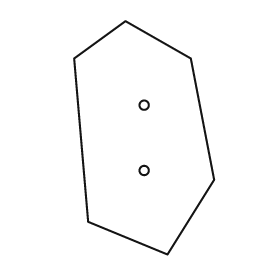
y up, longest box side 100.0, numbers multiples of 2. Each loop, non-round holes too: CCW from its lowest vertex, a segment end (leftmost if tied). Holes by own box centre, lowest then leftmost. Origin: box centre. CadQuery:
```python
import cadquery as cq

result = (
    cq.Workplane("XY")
    .moveTo(10.0, -50.0)
    .lineTo(30.0, -18.0)
    .lineTo(20.0, 34.0)
    .lineTo(-8.0, 50.0)
    .lineTo(-30.0, 34.0)
    .lineTo(-24.0, -36.0)
    .close()
    .moveTo(0.0, -14.0)
    .circle(2.0)
    .moveTo(0.0, 14.0)
    .circle(2.0)
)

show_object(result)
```